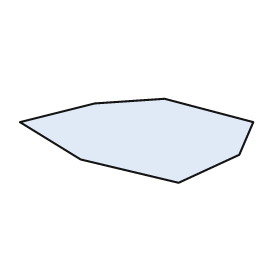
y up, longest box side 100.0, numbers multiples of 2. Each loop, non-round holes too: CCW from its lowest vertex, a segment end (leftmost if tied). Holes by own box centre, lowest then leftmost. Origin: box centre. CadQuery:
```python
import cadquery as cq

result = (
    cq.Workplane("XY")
    .moveTo(18.0, -18.0)
    .lineTo(44.0, -6.0)
    .lineTo(50.0, 8.0)
    .lineTo(12.0, 18.0)
    .lineTo(-18.0, 16.0)
    .lineTo(-50.0, 8.0)
    .lineTo(-24.0, -8.0)
    .close()
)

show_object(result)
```